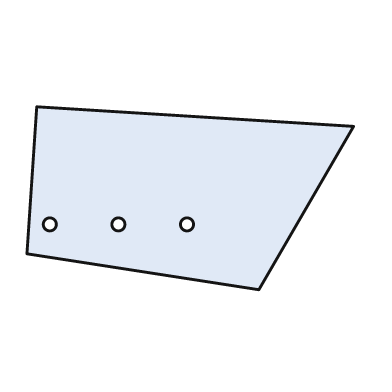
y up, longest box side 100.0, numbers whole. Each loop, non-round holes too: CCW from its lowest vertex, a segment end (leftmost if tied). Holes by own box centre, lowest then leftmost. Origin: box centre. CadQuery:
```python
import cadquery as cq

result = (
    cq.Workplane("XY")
    .moveTo(21.0, -28.0)
    .lineTo(50.0, 22.0)
    .lineTo(-47.0, 28.0)
    .lineTo(-50.0, -17.0)
    .close()
    .moveTo(-43.0, -8.0)
    .circle(2.0)
    .moveTo(-22.0, -8.0)
    .circle(2.0)
    .moveTo(-1.0, -8.0)
    .circle(2.0)
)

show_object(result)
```